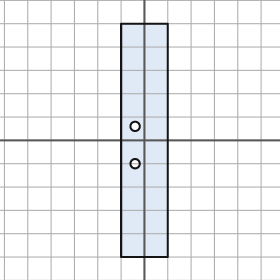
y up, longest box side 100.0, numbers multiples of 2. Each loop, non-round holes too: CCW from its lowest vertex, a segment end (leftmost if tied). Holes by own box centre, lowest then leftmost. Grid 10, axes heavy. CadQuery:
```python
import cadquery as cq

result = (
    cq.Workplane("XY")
    .moveTo(-10.0, -50.0)
    .lineTo(10.0, -50.0)
    .lineTo(10.0, 50.0)
    .lineTo(-10.0, 50.0)
    .close()
    .moveTo(-4.0, -10.0)
    .circle(2.0)
    .moveTo(-4.0, 6.0)
    .circle(2.0)
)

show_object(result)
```